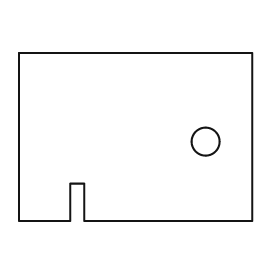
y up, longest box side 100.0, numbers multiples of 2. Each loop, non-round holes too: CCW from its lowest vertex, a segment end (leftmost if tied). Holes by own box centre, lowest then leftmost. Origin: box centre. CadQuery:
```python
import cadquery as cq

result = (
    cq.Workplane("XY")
    .moveTo(-50.0, -36.0)
    .lineTo(-28.0, -36.0)
    .lineTo(-28.0, -20.0)
    .lineTo(-22.0, -20.0)
    .lineTo(-22.0, -36.0)
    .lineTo(50.0, -36.0)
    .lineTo(50.0, 36.0)
    .lineTo(-50.0, 36.0)
    .close()
    .moveTo(30.0, -2.0)
    .circle(6.0)
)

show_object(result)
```